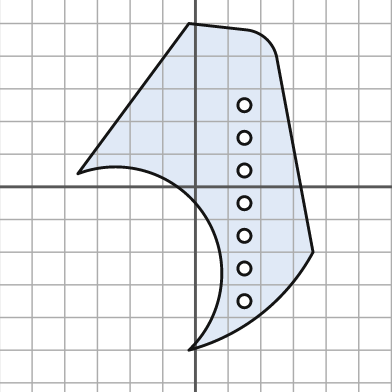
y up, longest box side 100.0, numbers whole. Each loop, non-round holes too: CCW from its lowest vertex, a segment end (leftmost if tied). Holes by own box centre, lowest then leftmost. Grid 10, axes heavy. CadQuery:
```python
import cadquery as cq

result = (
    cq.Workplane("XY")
    .moveTo(-2.0, -50.0)
    .threePointArc((20.0, -39.0), (36.0, -20.0))
    .lineTo(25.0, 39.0)
    .threePointArc((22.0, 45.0), (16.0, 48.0))
    .lineTo(-2.0, 50.0)
    .lineTo(-36.0, 4.0)
    .threePointArc((3.0, -9.0), (-2.0, -50.0))
    .close()
    .moveTo(15.0, -35.0)
    .circle(2.0)
    .moveTo(15.0, -25.0)
    .circle(2.0)
    .moveTo(15.0, -15.0)
    .circle(2.0)
    .moveTo(15.0, -5.0)
    .circle(2.0)
    .moveTo(15.0, 5.0)
    .circle(2.0)
    .moveTo(15.0, 15.0)
    .circle(2.0)
    .moveTo(15.0, 25.0)
    .circle(2.0)
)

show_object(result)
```